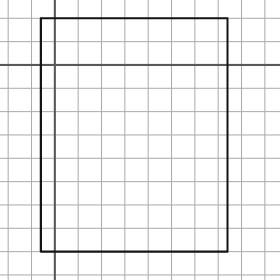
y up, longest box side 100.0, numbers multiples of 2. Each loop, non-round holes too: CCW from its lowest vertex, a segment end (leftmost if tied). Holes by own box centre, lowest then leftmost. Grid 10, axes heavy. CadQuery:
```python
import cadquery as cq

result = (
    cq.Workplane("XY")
    .moveTo(-6.0, -80.0)
    .lineTo(74.0, -80.0)
    .lineTo(74.0, 20.0)
    .lineTo(-6.0, 20.0)
    .close()
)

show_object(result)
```